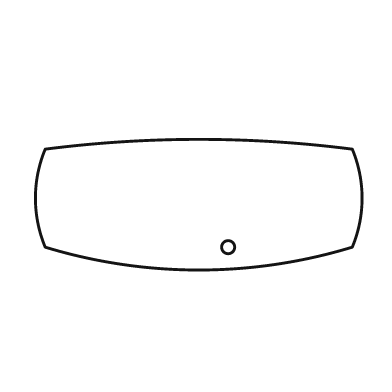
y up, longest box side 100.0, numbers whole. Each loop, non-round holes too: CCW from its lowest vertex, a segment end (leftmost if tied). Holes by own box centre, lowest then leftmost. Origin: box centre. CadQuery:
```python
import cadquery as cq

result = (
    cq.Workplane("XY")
    .moveTo(-47.0, -13.0)
    .threePointArc((0.0, -20.0), (47.0, -13.0))
    .threePointArc((50.0, 2.0), (47.0, 17.0))
    .threePointArc((0.0, 20.0), (-47.0, 17.0))
    .threePointArc((-50.0, 2.0), (-47.0, -13.0))
    .close()
    .moveTo(9.0, -13.0)
    .circle(2.0)
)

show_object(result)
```